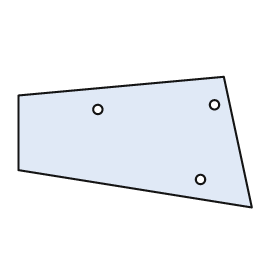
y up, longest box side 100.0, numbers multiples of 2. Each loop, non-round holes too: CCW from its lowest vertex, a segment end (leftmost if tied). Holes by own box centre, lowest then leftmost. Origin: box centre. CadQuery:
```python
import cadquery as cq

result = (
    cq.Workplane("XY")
    .moveTo(50.0, -28.0)
    .lineTo(38.0, 28.0)
    .lineTo(-50.0, 20.0)
    .lineTo(-50.0, -12.0)
    .close()
    .moveTo(28.0, -16.0)
    .circle(2.0)
    .moveTo(-16.0, 14.0)
    .circle(2.0)
    .moveTo(34.0, 16.0)
    .circle(2.0)
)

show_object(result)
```